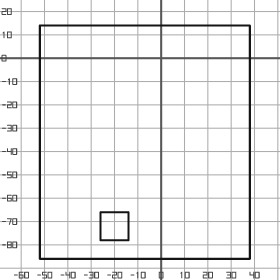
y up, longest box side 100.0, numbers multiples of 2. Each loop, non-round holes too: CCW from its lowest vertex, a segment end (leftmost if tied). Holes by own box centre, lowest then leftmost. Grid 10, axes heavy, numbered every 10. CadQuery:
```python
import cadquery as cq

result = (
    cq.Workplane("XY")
    .moveTo(-52.0, -86.0)
    .lineTo(38.0, -86.0)
    .lineTo(38.0, 14.0)
    .lineTo(-52.0, 14.0)
    .close()
    .moveTo(-26.0, -78.0)
    .lineTo(-14.0, -78.0)
    .lineTo(-14.0, -66.0)
    .lineTo(-26.0, -66.0)
    .close()
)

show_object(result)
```